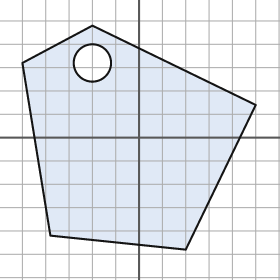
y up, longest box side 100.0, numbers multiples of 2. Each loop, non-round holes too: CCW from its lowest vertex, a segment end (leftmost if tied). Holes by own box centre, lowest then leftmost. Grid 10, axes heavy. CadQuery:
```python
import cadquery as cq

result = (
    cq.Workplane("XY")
    .moveTo(20.0, -48.0)
    .lineTo(50.0, 14.0)
    .lineTo(-20.0, 48.0)
    .lineTo(-50.0, 32.0)
    .lineTo(-38.0, -42.0)
    .close()
    .moveTo(-20.0, 32.0)
    .circle(8.0)
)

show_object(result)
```